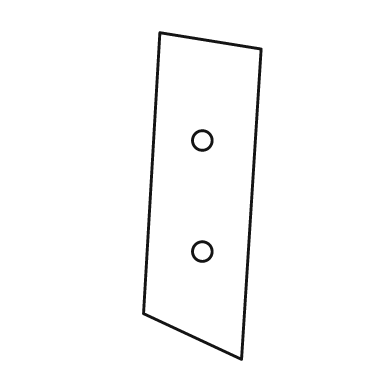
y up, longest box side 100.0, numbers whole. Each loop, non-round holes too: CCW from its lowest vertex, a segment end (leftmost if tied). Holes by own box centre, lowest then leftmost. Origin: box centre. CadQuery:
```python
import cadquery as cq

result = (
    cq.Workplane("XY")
    .moveTo(12.0, -50.0)
    .lineTo(18.0, 45.0)
    .lineTo(-13.0, 50.0)
    .lineTo(-18.0, -36.0)
    .close()
    .moveTo(0.0, -17.0)
    .circle(3.0)
    .moveTo(0.0, 17.0)
    .circle(3.0)
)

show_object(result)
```